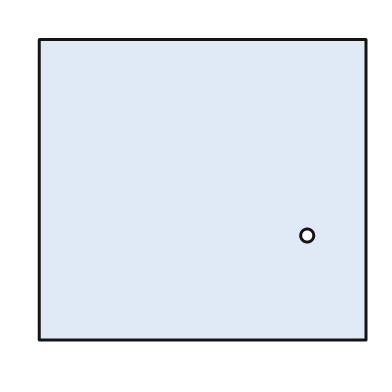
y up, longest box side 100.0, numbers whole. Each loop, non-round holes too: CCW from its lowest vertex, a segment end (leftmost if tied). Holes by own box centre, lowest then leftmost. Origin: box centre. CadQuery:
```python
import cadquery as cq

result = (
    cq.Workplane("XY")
    .moveTo(-50.0, -46.0)
    .lineTo(50.0, -46.0)
    .lineTo(50.0, 46.0)
    .lineTo(-50.0, 46.0)
    .close()
    .moveTo(32.0, -14.0)
    .circle(2.0)
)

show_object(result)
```